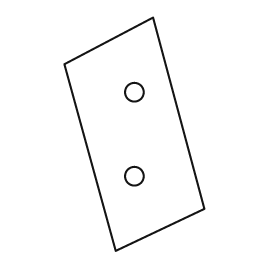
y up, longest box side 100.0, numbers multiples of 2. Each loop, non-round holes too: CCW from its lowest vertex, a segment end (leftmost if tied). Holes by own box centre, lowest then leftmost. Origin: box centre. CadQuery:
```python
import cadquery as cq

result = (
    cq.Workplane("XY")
    .moveTo(-8.0, -50.0)
    .lineTo(30.0, -32.0)
    .lineTo(8.0, 50.0)
    .lineTo(-30.0, 30.0)
    .close()
    .moveTo(0.0, -18.0)
    .circle(4.0)
    .moveTo(0.0, 18.0)
    .circle(4.0)
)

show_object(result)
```